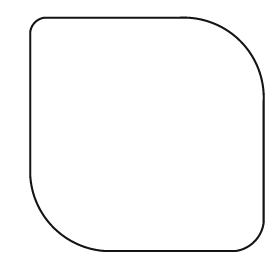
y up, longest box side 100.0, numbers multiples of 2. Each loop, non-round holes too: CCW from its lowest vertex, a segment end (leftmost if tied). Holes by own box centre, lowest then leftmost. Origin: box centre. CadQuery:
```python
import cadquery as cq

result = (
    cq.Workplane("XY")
    .moveTo(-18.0, -50.0)
    .lineTo(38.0, -50.0)
    .threePointArc((46.0, -46.0), (50.0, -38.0))
    .lineTo(50.0, 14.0)
    .threePointArc((40.0, 40.0), (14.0, 50.0))
    .lineTo(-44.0, 50.0)
    .threePointArc((-48.0, 48.0), (-50.0, 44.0))
    .lineTo(-50.0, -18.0)
    .threePointArc((-40.0, -40.0), (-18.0, -50.0))
    .close()
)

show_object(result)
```